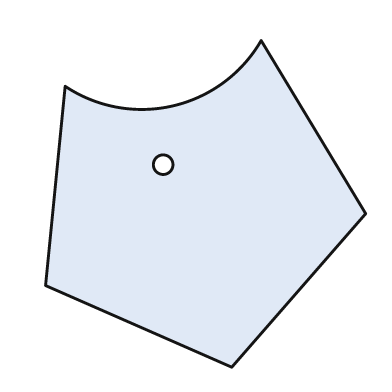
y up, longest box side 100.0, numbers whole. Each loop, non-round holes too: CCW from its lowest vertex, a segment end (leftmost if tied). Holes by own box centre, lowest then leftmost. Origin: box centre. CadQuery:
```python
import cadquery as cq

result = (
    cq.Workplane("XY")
    .moveTo(8.0, -50.0)
    .lineTo(49.0, -3.0)
    .lineTo(17.0, 50.0)
    .threePointArc((-10.0, 30.0), (-43.0, 36.0))
    .lineTo(-49.0, -25.0)
    .close()
    .moveTo(-13.0, 12.0)
    .circle(3.0)
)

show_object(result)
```